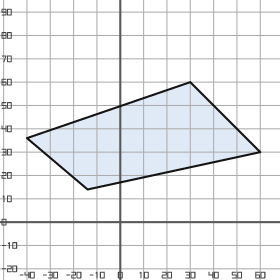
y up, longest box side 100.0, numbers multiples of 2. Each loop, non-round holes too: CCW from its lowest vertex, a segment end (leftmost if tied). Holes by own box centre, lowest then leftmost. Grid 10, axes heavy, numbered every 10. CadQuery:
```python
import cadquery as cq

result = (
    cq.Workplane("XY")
    .moveTo(-14.0, 14.0)
    .lineTo(60.0, 30.0)
    .lineTo(30.0, 60.0)
    .lineTo(-40.0, 36.0)
    .close()
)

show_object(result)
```